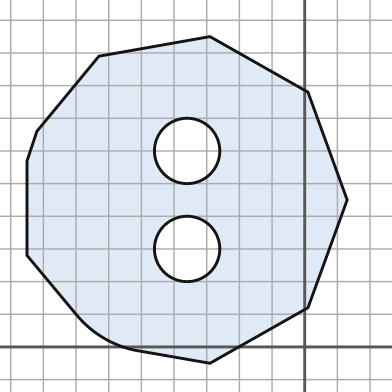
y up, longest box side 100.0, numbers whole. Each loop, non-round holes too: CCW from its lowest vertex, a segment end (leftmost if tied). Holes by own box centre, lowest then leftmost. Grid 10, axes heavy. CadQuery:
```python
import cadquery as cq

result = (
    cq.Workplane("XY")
    .moveTo(-29.0, -5.0)
    .lineTo(1.0, 12.0)
    .lineTo(13.0, 45.0)
    .lineTo(1.0, 78.0)
    .lineTo(-29.0, 95.0)
    .lineTo(-63.0, 89.0)
    .lineTo(-82.0, 66.0)
    .lineTo(-85.0, 57.0)
    .lineTo(-85.0, 28.0)
    .lineTo(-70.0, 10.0)
    .threePointArc((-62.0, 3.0), (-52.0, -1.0))
    .close()
    .moveTo(-36.0, 30.0)
    .circle(10.0)
    .moveTo(-36.0, 60.0)
    .circle(10.0)
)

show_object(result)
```